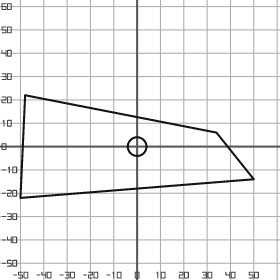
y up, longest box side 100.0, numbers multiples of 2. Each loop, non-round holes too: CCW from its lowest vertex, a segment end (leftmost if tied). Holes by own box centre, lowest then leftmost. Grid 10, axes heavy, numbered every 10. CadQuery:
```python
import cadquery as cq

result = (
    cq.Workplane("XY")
    .moveTo(-50.0, -22.0)
    .lineTo(50.0, -14.0)
    .lineTo(34.0, 6.0)
    .lineTo(-48.0, 22.0)
    .close()
    .moveTo(0.0, 0.0)
    .circle(4.0)
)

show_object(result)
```